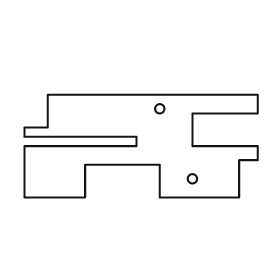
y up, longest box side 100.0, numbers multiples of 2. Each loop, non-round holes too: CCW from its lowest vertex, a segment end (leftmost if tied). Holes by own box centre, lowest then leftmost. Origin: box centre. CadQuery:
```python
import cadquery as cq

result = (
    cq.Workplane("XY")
    .moveTo(-50.0, -22.0)
    .lineTo(-24.0, -22.0)
    .lineTo(-24.0, -8.0)
    .lineTo(8.0, -8.0)
    .lineTo(8.0, -22.0)
    .lineTo(42.0, -22.0)
    .lineTo(42.0, -6.0)
    .lineTo(50.0, -6.0)
    .lineTo(50.0, 0.0)
    .lineTo(22.0, 0.0)
    .lineTo(22.0, 14.0)
    .lineTo(50.0, 14.0)
    .lineTo(50.0, 22.0)
    .lineTo(-40.0, 22.0)
    .lineTo(-40.0, 8.0)
    .lineTo(-50.0, 8.0)
    .lineTo(-50.0, 4.0)
    .lineTo(-2.0, 4.0)
    .lineTo(-2.0, 0.0)
    .lineTo(-50.0, 0.0)
    .close()
    .moveTo(22.0, -14.0)
    .circle(2.0)
    .moveTo(8.0, 16.0)
    .circle(2.0)
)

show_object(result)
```